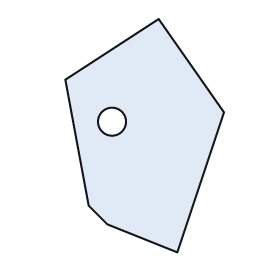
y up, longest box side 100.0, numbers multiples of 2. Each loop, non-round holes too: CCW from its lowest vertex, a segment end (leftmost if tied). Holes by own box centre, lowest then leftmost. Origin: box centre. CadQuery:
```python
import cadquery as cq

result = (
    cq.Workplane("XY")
    .moveTo(14.0, -50.0)
    .lineTo(34.0, 10.0)
    .lineTo(6.0, 50.0)
    .lineTo(-34.0, 24.0)
    .lineTo(-24.0, -30.0)
    .lineTo(-16.0, -38.0)
    .close()
    .moveTo(-14.0, 6.0)
    .circle(6.0)
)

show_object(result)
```